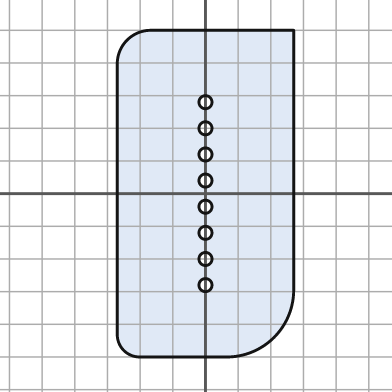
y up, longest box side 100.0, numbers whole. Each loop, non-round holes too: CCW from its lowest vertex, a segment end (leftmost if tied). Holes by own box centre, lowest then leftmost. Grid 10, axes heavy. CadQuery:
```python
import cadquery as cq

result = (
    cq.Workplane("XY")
    .moveTo(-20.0, -50.0)
    .lineTo(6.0, -50.0)
    .threePointArc((21.0, -44.0), (27.0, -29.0))
    .lineTo(27.0, 50.0)
    .lineTo(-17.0, 50.0)
    .threePointArc((-24.0, 47.0), (-27.0, 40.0))
    .lineTo(-27.0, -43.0)
    .threePointArc((-25.0, -48.0), (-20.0, -50.0))
    .close()
    .moveTo(0.0, -28.0)
    .circle(2.0)
    .moveTo(0.0, -20.0)
    .circle(2.0)
    .moveTo(0.0, -12.0)
    .circle(2.0)
    .moveTo(0.0, -4.0)
    .circle(2.0)
    .moveTo(0.0, 4.0)
    .circle(2.0)
    .moveTo(0.0, 12.0)
    .circle(2.0)
    .moveTo(0.0, 20.0)
    .circle(2.0)
    .moveTo(0.0, 28.0)
    .circle(2.0)
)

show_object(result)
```